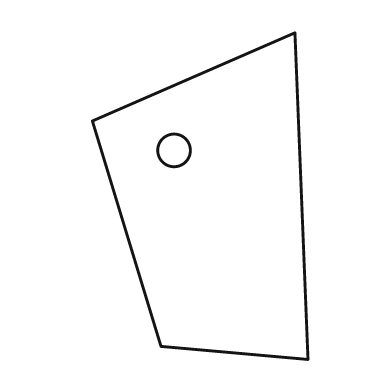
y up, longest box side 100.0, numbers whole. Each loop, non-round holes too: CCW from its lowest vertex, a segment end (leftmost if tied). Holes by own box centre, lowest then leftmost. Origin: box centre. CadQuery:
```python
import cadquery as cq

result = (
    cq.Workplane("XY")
    .moveTo(33.0, -50.0)
    .lineTo(29.0, 50.0)
    .lineTo(-33.0, 23.0)
    .lineTo(-12.0, -46.0)
    .close()
    .moveTo(-8.0, 14.0)
    .circle(5.0)
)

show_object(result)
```